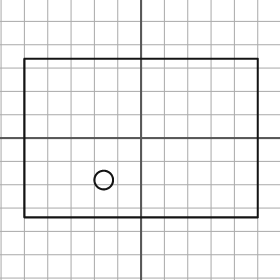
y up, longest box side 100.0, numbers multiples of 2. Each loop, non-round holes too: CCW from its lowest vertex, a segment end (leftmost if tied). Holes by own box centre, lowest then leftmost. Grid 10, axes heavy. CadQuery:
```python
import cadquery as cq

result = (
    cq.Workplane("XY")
    .moveTo(-50.0, -34.0)
    .lineTo(50.0, -34.0)
    .lineTo(50.0, 34.0)
    .lineTo(-50.0, 34.0)
    .close()
    .moveTo(-16.0, -18.0)
    .circle(4.0)
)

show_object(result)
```